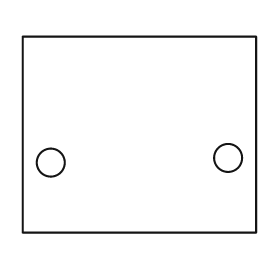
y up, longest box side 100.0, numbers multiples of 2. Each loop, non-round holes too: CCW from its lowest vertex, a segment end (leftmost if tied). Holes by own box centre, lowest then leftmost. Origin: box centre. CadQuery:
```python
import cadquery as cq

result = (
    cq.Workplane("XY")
    .moveTo(-50.0, -42.0)
    .lineTo(50.0, -42.0)
    .lineTo(50.0, 42.0)
    .lineTo(-50.0, 42.0)
    .close()
    .moveTo(-38.0, -12.0)
    .circle(6.0)
    .moveTo(38.0, -10.0)
    .circle(6.0)
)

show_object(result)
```